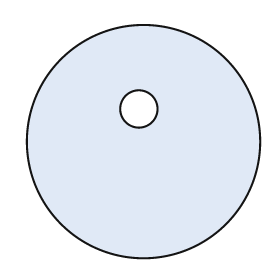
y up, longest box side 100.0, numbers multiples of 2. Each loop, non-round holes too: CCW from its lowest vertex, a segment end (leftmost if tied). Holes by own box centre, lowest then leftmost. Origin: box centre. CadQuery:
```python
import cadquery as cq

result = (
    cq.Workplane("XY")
    .moveTo(0.0, 0.0)
    .circle(50.0)
    .moveTo(-2.0, 14.0)
    .circle(8.0)
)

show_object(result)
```